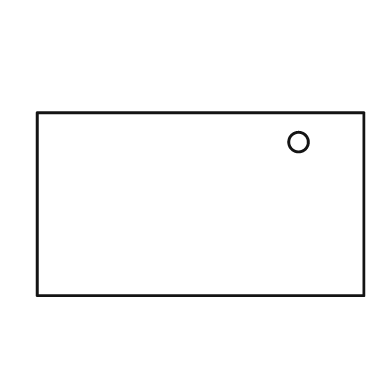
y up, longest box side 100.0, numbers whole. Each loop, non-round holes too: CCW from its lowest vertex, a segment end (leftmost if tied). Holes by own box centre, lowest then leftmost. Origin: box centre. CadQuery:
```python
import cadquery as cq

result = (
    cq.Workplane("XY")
    .moveTo(-50.0, -28.0)
    .lineTo(50.0, -28.0)
    .lineTo(50.0, 28.0)
    .lineTo(-50.0, 28.0)
    .close()
    .moveTo(30.0, 19.0)
    .circle(3.0)
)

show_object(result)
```